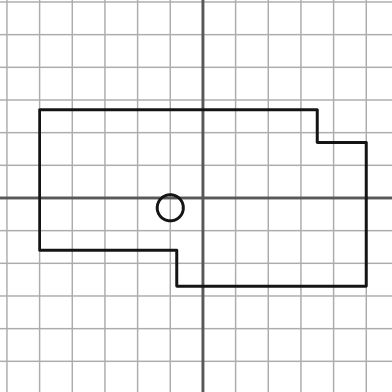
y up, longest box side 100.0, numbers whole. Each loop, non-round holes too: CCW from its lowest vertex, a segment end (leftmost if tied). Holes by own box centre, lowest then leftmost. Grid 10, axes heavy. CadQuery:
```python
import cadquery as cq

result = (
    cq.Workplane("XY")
    .moveTo(-8.0, -27.0)
    .lineTo(50.0, -27.0)
    .lineTo(50.0, 17.0)
    .lineTo(35.0, 17.0)
    .lineTo(35.0, 27.0)
    .lineTo(-50.0, 27.0)
    .lineTo(-50.0, -16.0)
    .lineTo(-8.0, -16.0)
    .close()
    .moveTo(-10.0, -3.0)
    .circle(4.0)
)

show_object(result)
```